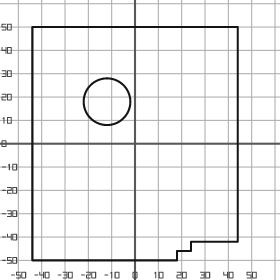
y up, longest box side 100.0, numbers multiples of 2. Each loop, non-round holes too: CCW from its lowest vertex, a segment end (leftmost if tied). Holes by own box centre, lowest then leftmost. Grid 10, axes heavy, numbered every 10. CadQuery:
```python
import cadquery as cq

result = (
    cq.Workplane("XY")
    .moveTo(-44.0, -50.0)
    .lineTo(18.0, -50.0)
    .lineTo(18.0, -46.0)
    .lineTo(24.0, -46.0)
    .lineTo(24.0, -42.0)
    .lineTo(44.0, -42.0)
    .lineTo(44.0, 50.0)
    .lineTo(-44.0, 50.0)
    .close()
    .moveTo(-12.0, 18.0)
    .circle(10.0)
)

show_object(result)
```